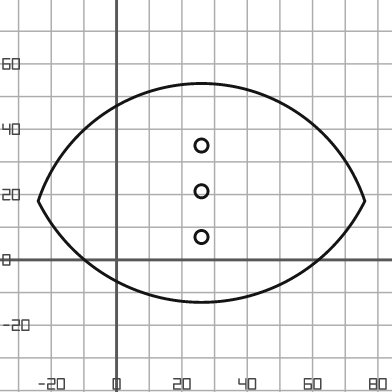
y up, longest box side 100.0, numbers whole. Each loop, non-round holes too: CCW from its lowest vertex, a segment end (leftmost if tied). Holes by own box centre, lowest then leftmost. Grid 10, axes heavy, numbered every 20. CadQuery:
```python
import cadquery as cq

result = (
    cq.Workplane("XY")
    .moveTo(-24.0, 18.0)
    .threePointArc((26.0, -13.0), (76.0, 18.0))
    .threePointArc((26.0, 54.0), (-24.0, 18.0))
    .close()
    .moveTo(26.0, 7.0)
    .circle(2.0)
    .moveTo(26.0, 21.0)
    .circle(2.0)
    .moveTo(26.0, 35.0)
    .circle(2.0)
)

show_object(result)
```